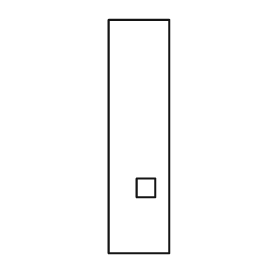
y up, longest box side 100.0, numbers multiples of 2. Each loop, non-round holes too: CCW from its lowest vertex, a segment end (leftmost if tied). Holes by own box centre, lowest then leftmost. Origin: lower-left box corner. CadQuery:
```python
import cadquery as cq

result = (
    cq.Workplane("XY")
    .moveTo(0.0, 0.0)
    .lineTo(26.0, 0.0)
    .lineTo(26.0, 100.0)
    .lineTo(0.0, 100.0)
    .close()
    .moveTo(12.0, 24.0)
    .lineTo(20.0, 24.0)
    .lineTo(20.0, 32.0)
    .lineTo(12.0, 32.0)
    .close()
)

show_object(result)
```